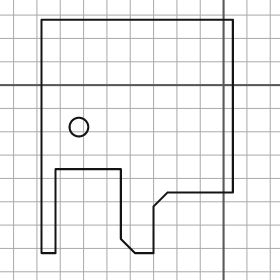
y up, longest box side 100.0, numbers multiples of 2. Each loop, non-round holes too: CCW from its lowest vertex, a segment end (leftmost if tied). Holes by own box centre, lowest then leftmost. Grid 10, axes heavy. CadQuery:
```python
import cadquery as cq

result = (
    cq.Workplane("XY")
    .moveTo(-78.0, -72.0)
    .lineTo(-72.0, -72.0)
    .lineTo(-72.0, -36.0)
    .lineTo(-44.0, -36.0)
    .lineTo(-44.0, -66.0)
    .lineTo(-38.0, -72.0)
    .lineTo(-30.0, -72.0)
    .lineTo(-30.0, -52.0)
    .lineTo(-24.0, -46.0)
    .lineTo(4.0, -46.0)
    .lineTo(4.0, 28.0)
    .lineTo(-78.0, 28.0)
    .close()
    .moveTo(-62.0, -18.0)
    .circle(4.0)
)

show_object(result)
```